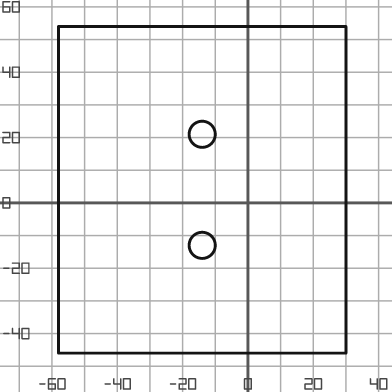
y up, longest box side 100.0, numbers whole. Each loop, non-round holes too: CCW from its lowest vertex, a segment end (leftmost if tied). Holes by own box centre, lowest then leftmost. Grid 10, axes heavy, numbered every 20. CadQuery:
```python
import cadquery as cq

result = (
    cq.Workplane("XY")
    .moveTo(-58.0, -46.0)
    .lineTo(30.0, -46.0)
    .lineTo(30.0, 54.0)
    .lineTo(-58.0, 54.0)
    .close()
    .moveTo(-14.0, -13.0)
    .circle(4.0)
    .moveTo(-14.0, 21.0)
    .circle(4.0)
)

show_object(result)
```